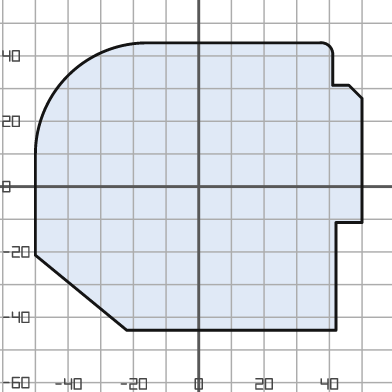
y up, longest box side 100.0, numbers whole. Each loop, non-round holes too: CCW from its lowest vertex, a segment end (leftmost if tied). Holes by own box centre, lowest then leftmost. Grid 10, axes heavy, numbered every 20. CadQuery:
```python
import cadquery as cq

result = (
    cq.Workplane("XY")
    .moveTo(-22.0, -44.0)
    .lineTo(42.0, -44.0)
    .lineTo(42.0, -11.0)
    .lineTo(50.0, -11.0)
    .lineTo(50.0, 27.0)
    .lineTo(46.0, 31.0)
    .lineTo(41.0, 31.0)
    .lineTo(41.0, 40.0)
    .threePointArc((40.0, 43.0), (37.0, 44.0))
    .lineTo(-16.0, 44.0)
    .threePointArc((-40.0, 34.0), (-50.0, 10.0))
    .lineTo(-50.0, -21.0)
    .close()
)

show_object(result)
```